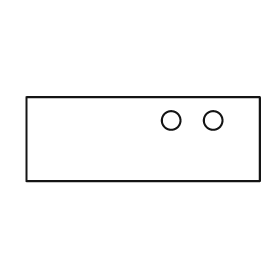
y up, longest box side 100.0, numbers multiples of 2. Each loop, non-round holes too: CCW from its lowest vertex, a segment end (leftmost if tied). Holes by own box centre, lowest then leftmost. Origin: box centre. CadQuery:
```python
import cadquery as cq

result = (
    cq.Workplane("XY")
    .moveTo(-50.0, -18.0)
    .lineTo(50.0, -18.0)
    .lineTo(50.0, 18.0)
    .lineTo(-50.0, 18.0)
    .close()
    .moveTo(12.0, 8.0)
    .circle(4.0)
    .moveTo(30.0, 8.0)
    .circle(4.0)
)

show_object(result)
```